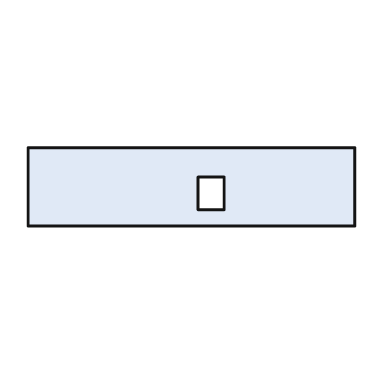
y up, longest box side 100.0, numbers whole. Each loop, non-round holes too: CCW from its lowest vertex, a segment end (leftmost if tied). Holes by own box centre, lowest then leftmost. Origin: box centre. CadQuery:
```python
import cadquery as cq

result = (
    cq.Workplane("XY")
    .moveTo(-50.0, -12.0)
    .lineTo(50.0, -12.0)
    .lineTo(50.0, 12.0)
    .lineTo(-50.0, 12.0)
    .close()
    .moveTo(2.0, -7.0)
    .lineTo(10.0, -7.0)
    .lineTo(10.0, 3.0)
    .lineTo(2.0, 3.0)
    .close()
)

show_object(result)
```